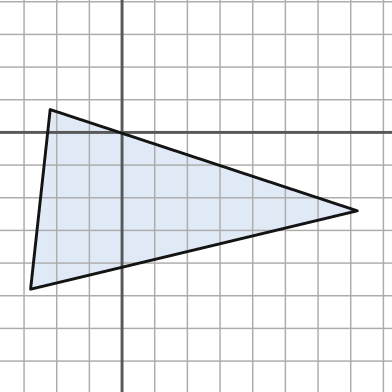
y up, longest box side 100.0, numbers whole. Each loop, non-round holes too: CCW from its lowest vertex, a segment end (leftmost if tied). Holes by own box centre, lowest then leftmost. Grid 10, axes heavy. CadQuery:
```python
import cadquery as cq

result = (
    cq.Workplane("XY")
    .moveTo(-28.0, -48.0)
    .lineTo(72.0, -24.0)
    .lineTo(-22.0, 7.0)
    .close()
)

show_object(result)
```